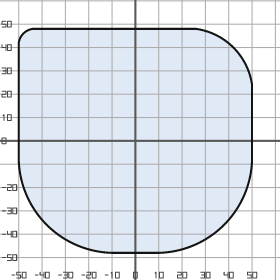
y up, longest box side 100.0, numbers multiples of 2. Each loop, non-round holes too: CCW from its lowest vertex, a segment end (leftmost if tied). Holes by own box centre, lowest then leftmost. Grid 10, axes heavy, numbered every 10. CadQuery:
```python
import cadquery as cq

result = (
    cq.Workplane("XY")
    .moveTo(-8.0, -48.0)
    .lineTo(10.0, -48.0)
    .threePointArc((38.0, -36.0), (50.0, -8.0))
    .lineTo(50.0, 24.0)
    .threePointArc((42.0, 40.0), (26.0, 48.0))
    .lineTo(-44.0, 48.0)
    .threePointArc((-48.0, 46.0), (-50.0, 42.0))
    .lineTo(-50.0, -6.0)
    .threePointArc((-38.0, -36.0), (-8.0, -48.0))
    .close()
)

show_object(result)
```